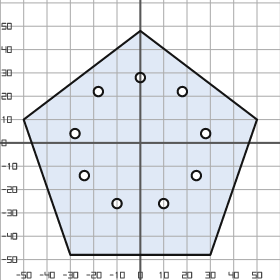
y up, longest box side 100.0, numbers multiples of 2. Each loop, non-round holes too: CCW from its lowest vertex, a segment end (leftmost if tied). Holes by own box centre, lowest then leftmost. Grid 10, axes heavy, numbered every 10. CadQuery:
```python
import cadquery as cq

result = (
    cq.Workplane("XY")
    .moveTo(-30.0, -48.0)
    .lineTo(30.0, -48.0)
    .lineTo(50.0, 10.0)
    .lineTo(0.0, 48.0)
    .lineTo(-50.0, 10.0)
    .close()
    .moveTo(-10.0, -26.0)
    .circle(2.0)
    .moveTo(10.0, -26.0)
    .circle(2.0)
    .moveTo(-24.0, -14.0)
    .circle(2.0)
    .moveTo(24.0, -14.0)
    .circle(2.0)
    .moveTo(-28.0, 4.0)
    .circle(2.0)
    .moveTo(28.0, 4.0)
    .circle(2.0)
    .moveTo(-18.0, 22.0)
    .circle(2.0)
    .moveTo(18.0, 22.0)
    .circle(2.0)
    .moveTo(0.0, 28.0)
    .circle(2.0)
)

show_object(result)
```